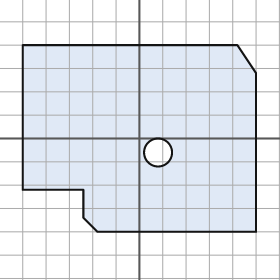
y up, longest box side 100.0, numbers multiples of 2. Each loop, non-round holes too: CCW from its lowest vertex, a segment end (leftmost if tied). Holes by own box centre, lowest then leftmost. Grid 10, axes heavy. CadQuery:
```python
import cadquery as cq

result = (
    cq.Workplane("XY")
    .moveTo(-18.0, -40.0)
    .lineTo(50.0, -40.0)
    .lineTo(50.0, 28.0)
    .lineTo(42.0, 40.0)
    .lineTo(-50.0, 40.0)
    .lineTo(-50.0, -22.0)
    .lineTo(-24.0, -22.0)
    .lineTo(-24.0, -34.0)
    .close()
    .moveTo(8.0, -6.0)
    .circle(6.0)
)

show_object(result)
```